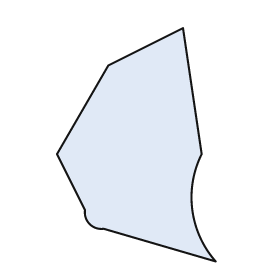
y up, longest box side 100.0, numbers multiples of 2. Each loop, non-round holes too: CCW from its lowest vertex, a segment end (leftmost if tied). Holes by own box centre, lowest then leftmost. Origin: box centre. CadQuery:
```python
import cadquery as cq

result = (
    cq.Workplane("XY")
    .moveTo(34.0, -50.0)
    .threePointArc((24.0, -28.0), (28.0, -4.0))
    .lineTo(20.0, 50.0)
    .lineTo(-12.0, 34.0)
    .lineTo(-34.0, -4.0)
    .lineTo(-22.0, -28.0)
    .threePointArc((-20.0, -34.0), (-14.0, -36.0))
    .close()
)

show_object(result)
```